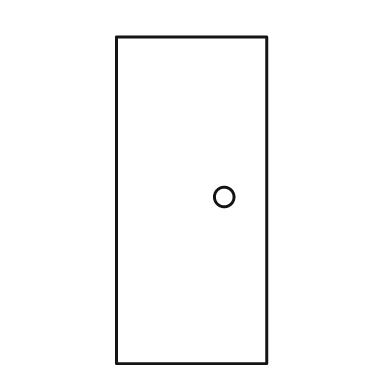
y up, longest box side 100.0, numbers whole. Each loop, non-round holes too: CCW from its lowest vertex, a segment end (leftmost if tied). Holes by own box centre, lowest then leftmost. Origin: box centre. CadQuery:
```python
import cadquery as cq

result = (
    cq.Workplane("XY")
    .moveTo(-23.0, -50.0)
    .lineTo(23.0, -50.0)
    .lineTo(23.0, 50.0)
    .lineTo(-23.0, 50.0)
    .close()
    .moveTo(10.0, 1.0)
    .circle(3.0)
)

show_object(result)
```